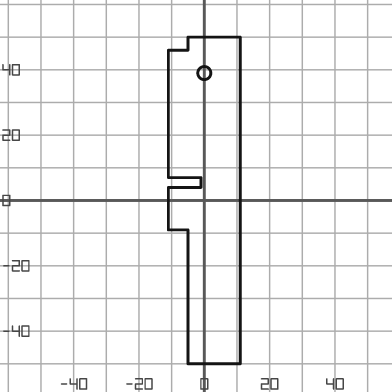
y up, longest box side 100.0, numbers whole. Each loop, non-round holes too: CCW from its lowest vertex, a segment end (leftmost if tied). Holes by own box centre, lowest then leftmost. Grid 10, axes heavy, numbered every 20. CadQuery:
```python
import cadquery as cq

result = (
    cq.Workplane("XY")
    .moveTo(-5.0, -50.0)
    .lineTo(11.0, -50.0)
    .lineTo(11.0, 50.0)
    .lineTo(-5.0, 50.0)
    .lineTo(-5.0, 46.0)
    .lineTo(-11.0, 46.0)
    .lineTo(-11.0, 7.0)
    .lineTo(-1.0, 7.0)
    .lineTo(-1.0, 4.0)
    .lineTo(-11.0, 4.0)
    .lineTo(-11.0, -9.0)
    .lineTo(-5.0, -9.0)
    .close()
    .moveTo(0.0, 39.0)
    .circle(2.0)
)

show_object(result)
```